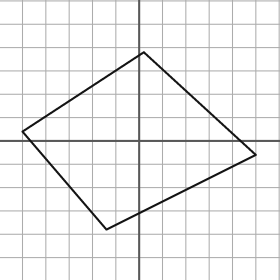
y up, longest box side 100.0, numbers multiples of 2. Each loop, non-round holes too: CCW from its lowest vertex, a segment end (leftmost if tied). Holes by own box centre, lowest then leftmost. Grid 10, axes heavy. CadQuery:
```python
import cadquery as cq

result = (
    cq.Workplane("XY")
    .moveTo(-14.0, -38.0)
    .lineTo(50.0, -6.0)
    .lineTo(2.0, 38.0)
    .lineTo(-50.0, 4.0)
    .close()
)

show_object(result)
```